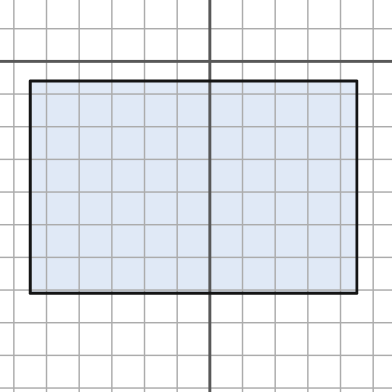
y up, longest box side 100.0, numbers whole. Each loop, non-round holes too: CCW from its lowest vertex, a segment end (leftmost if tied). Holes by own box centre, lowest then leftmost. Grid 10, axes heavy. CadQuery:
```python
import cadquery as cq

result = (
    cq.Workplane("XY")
    .moveTo(-55.0, -71.0)
    .lineTo(45.0, -71.0)
    .lineTo(45.0, -6.0)
    .lineTo(-55.0, -6.0)
    .close()
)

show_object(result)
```